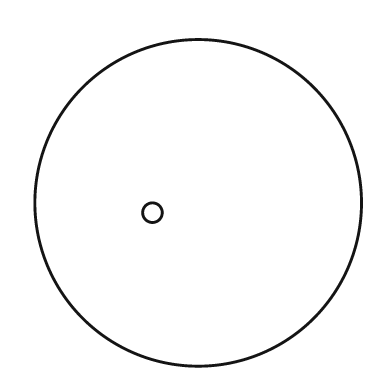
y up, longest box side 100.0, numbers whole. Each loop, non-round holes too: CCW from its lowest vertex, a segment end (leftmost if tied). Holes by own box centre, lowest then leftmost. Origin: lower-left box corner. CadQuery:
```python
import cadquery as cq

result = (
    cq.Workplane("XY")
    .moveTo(50.0, 50.0)
    .circle(50.0)
    .moveTo(36.0, 47.0)
    .circle(3.0)
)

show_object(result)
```